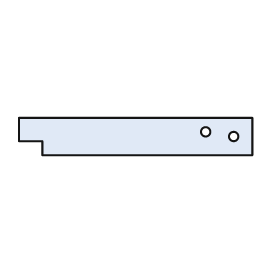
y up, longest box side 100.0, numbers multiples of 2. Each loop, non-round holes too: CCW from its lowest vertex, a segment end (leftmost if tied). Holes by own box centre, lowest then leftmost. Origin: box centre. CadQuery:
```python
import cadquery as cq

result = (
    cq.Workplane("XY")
    .moveTo(-40.0, -8.0)
    .lineTo(50.0, -8.0)
    .lineTo(50.0, 8.0)
    .lineTo(-50.0, 8.0)
    .lineTo(-50.0, -2.0)
    .lineTo(-40.0, -2.0)
    .close()
    .moveTo(42.0, 0.0)
    .circle(2.0)
    .moveTo(30.0, 2.0)
    .circle(2.0)
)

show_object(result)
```